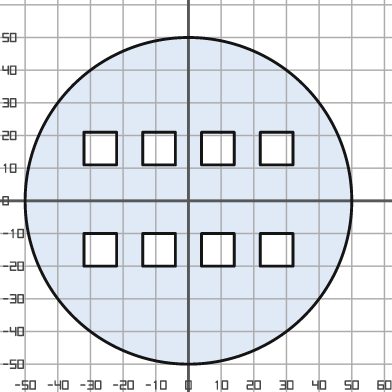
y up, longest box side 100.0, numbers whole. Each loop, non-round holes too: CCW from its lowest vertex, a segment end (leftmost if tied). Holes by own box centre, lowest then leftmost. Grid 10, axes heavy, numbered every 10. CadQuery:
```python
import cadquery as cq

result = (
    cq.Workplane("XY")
    .moveTo(0.0, 0.0)
    .circle(50.0)
    .moveTo(-32.0, -20.0)
    .lineTo(-22.0, -20.0)
    .lineTo(-22.0, -10.0)
    .lineTo(-32.0, -10.0)
    .close()
    .moveTo(-14.0, -20.0)
    .lineTo(-4.0, -20.0)
    .lineTo(-4.0, -10.0)
    .lineTo(-14.0, -10.0)
    .close()
    .moveTo(4.0, -20.0)
    .lineTo(14.0, -20.0)
    .lineTo(14.0, -10.0)
    .lineTo(4.0, -10.0)
    .close()
    .moveTo(22.0, -20.0)
    .lineTo(32.0, -20.0)
    .lineTo(32.0, -10.0)
    .lineTo(22.0, -10.0)
    .close()
    .moveTo(-32.0, 11.0)
    .lineTo(-22.0, 11.0)
    .lineTo(-22.0, 21.0)
    .lineTo(-32.0, 21.0)
    .close()
    .moveTo(-14.0, 11.0)
    .lineTo(-4.0, 11.0)
    .lineTo(-4.0, 21.0)
    .lineTo(-14.0, 21.0)
    .close()
    .moveTo(4.0, 11.0)
    .lineTo(14.0, 11.0)
    .lineTo(14.0, 21.0)
    .lineTo(4.0, 21.0)
    .close()
    .moveTo(22.0, 11.0)
    .lineTo(32.0, 11.0)
    .lineTo(32.0, 21.0)
    .lineTo(22.0, 21.0)
    .close()
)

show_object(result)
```